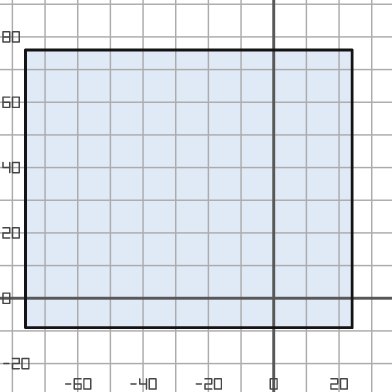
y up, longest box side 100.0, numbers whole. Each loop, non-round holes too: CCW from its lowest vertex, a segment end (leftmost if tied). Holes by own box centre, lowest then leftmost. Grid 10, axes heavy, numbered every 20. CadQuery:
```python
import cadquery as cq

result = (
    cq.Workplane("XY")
    .moveTo(-76.0, -9.0)
    .lineTo(24.0, -9.0)
    .lineTo(24.0, 76.0)
    .lineTo(-76.0, 76.0)
    .close()
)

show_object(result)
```